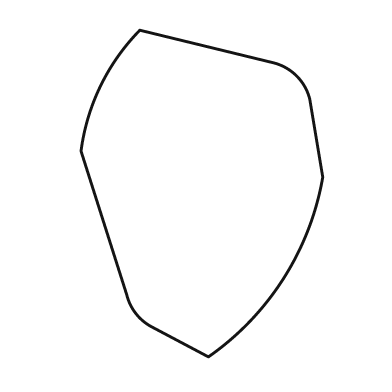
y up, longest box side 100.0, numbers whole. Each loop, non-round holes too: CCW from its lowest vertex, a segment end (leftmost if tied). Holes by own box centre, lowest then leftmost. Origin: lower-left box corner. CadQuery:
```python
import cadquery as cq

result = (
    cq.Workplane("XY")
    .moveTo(39.0, 0.0)
    .threePointArc((62.0, 24.0), (74.0, 55.0))
    .lineTo(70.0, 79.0)
    .threePointArc((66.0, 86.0), (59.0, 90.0))
    .lineTo(18.0, 100.0)
    .threePointArc((6.0, 83.0), (0.0, 63.0))
    .lineTo(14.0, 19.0)
    .threePointArc((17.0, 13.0), (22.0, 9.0))
    .close()
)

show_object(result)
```